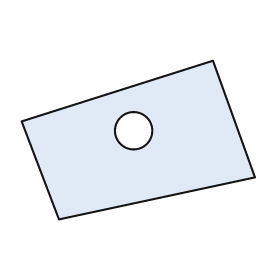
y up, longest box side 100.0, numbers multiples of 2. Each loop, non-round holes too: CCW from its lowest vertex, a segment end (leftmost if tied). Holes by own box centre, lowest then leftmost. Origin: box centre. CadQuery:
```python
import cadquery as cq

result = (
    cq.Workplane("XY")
    .moveTo(-34.0, -34.0)
    .lineTo(50.0, -16.0)
    .lineTo(32.0, 34.0)
    .lineTo(-50.0, 8.0)
    .close()
    .moveTo(-2.0, 4.0)
    .circle(8.0)
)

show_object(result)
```